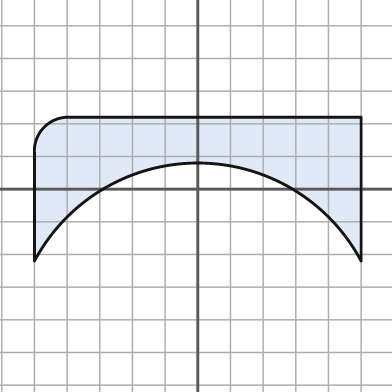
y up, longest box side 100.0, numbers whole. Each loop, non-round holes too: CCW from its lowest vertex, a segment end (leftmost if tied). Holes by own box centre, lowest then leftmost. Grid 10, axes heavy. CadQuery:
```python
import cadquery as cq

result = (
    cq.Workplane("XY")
    .moveTo(-50.0, -22.0)
    .threePointArc((0.0, 8.0), (50.0, -22.0))
    .lineTo(50.0, 22.0)
    .lineTo(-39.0, 22.0)
    .threePointArc((-47.0, 19.0), (-50.0, 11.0))
    .close()
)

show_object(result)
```